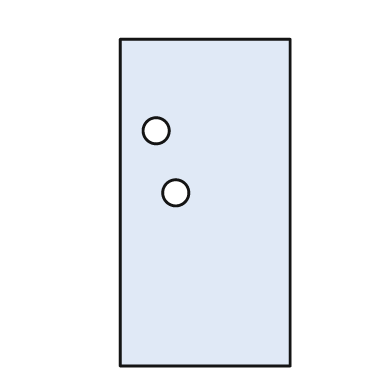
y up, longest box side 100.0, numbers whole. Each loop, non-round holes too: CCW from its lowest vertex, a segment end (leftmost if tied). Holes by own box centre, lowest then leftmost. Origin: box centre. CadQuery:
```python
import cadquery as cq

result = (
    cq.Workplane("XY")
    .moveTo(-26.0, -50.0)
    .lineTo(26.0, -50.0)
    .lineTo(26.0, 50.0)
    .lineTo(-26.0, 50.0)
    .close()
    .moveTo(-9.0, 3.0)
    .circle(4.0)
    .moveTo(-15.0, 22.0)
    .circle(4.0)
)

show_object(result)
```